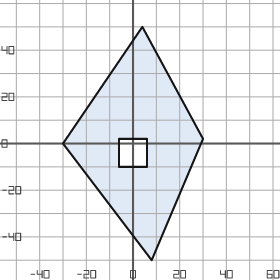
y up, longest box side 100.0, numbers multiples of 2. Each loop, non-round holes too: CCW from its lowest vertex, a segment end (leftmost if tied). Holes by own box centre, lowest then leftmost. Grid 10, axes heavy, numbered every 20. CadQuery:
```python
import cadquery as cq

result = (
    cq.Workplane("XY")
    .moveTo(8.0, -50.0)
    .lineTo(30.0, 2.0)
    .lineTo(4.0, 50.0)
    .lineTo(-30.0, 0.0)
    .close()
    .moveTo(-6.0, -10.0)
    .lineTo(6.0, -10.0)
    .lineTo(6.0, 2.0)
    .lineTo(-6.0, 2.0)
    .close()
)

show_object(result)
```